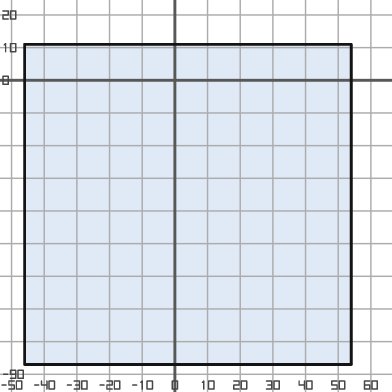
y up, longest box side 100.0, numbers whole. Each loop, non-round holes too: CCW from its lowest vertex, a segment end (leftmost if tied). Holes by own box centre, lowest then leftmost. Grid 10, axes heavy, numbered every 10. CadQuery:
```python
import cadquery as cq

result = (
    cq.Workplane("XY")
    .moveTo(-46.0, -87.0)
    .lineTo(54.0, -87.0)
    .lineTo(54.0, 11.0)
    .lineTo(-46.0, 11.0)
    .close()
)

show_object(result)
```